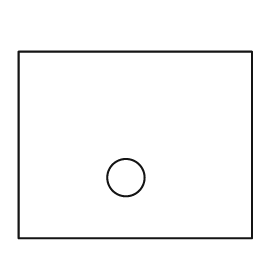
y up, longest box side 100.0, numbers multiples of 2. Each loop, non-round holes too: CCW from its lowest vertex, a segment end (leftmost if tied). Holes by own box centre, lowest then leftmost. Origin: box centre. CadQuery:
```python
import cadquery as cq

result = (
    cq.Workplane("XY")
    .moveTo(-50.0, -40.0)
    .lineTo(50.0, -40.0)
    .lineTo(50.0, 40.0)
    .lineTo(-50.0, 40.0)
    .close()
    .moveTo(-4.0, -14.0)
    .circle(8.0)
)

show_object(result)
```